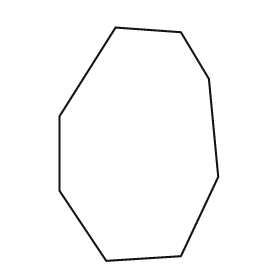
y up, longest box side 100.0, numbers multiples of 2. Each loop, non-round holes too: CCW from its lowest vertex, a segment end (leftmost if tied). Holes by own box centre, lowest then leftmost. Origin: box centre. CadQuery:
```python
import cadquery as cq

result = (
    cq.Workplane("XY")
    .moveTo(-14.0, -50.0)
    .lineTo(18.0, -48.0)
    .lineTo(34.0, -14.0)
    .lineTo(30.0, 28.0)
    .lineTo(18.0, 48.0)
    .lineTo(-10.0, 50.0)
    .lineTo(-34.0, 12.0)
    .lineTo(-34.0, -20.0)
    .close()
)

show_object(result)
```